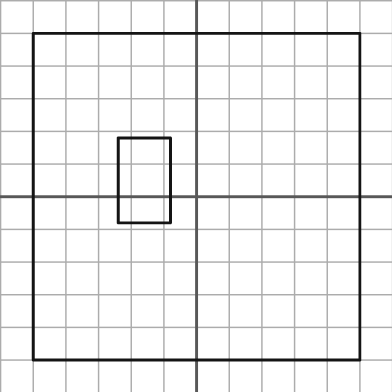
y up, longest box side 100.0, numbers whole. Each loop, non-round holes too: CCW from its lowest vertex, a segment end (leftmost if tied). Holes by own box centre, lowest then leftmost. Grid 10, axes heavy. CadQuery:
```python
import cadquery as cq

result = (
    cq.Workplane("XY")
    .moveTo(-50.0, -50.0)
    .lineTo(50.0, -50.0)
    .lineTo(50.0, 50.0)
    .lineTo(-50.0, 50.0)
    .close()
    .moveTo(-24.0, -8.0)
    .lineTo(-8.0, -8.0)
    .lineTo(-8.0, 18.0)
    .lineTo(-24.0, 18.0)
    .close()
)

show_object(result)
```